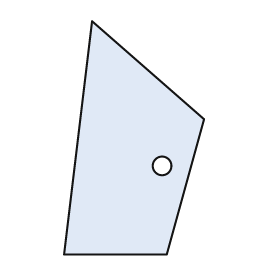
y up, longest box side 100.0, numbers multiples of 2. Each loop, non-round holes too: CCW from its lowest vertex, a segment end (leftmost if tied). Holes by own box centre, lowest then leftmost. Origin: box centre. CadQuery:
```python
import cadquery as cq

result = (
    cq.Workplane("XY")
    .moveTo(-30.0, -50.0)
    .lineTo(14.0, -50.0)
    .lineTo(30.0, 8.0)
    .lineTo(-18.0, 50.0)
    .close()
    .moveTo(12.0, -12.0)
    .circle(4.0)
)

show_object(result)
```